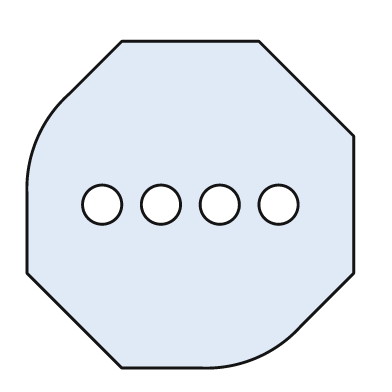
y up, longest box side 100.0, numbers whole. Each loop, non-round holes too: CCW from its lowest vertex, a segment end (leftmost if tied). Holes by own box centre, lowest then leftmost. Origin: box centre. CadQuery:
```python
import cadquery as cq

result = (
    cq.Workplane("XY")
    .moveTo(-21.0, -50.0)
    .lineTo(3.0, -50.0)
    .threePointArc((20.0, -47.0), (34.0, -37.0))
    .lineTo(50.0, -21.0)
    .lineTo(50.0, 21.0)
    .lineTo(21.0, 50.0)
    .lineTo(-21.0, 50.0)
    .lineTo(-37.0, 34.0)
    .threePointArc((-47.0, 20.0), (-50.0, 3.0))
    .lineTo(-50.0, -21.0)
    .close()
    .moveTo(-27.0, 0.0)
    .circle(6.0)
    .moveTo(-9.0, 0.0)
    .circle(6.0)
    .moveTo(9.0, 0.0)
    .circle(6.0)
    .moveTo(27.0, 0.0)
    .circle(6.0)
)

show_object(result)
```